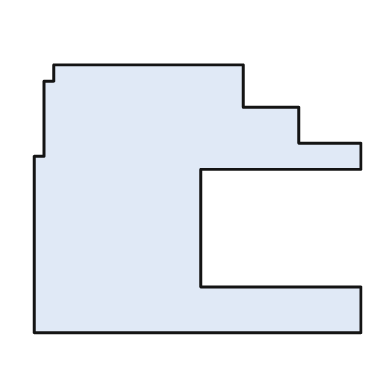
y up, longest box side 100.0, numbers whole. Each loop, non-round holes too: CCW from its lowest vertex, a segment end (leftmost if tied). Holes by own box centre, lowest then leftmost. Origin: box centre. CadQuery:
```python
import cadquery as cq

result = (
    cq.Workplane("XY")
    .moveTo(-50.0, -41.0)
    .lineTo(50.0, -41.0)
    .lineTo(50.0, -27.0)
    .lineTo(1.0, -27.0)
    .lineTo(1.0, 9.0)
    .lineTo(50.0, 9.0)
    .lineTo(50.0, 17.0)
    .lineTo(31.0, 17.0)
    .lineTo(31.0, 28.0)
    .lineTo(14.0, 28.0)
    .lineTo(14.0, 41.0)
    .lineTo(-44.0, 41.0)
    .lineTo(-44.0, 36.0)
    .lineTo(-47.0, 36.0)
    .lineTo(-47.0, 13.0)
    .lineTo(-50.0, 13.0)
    .close()
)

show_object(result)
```